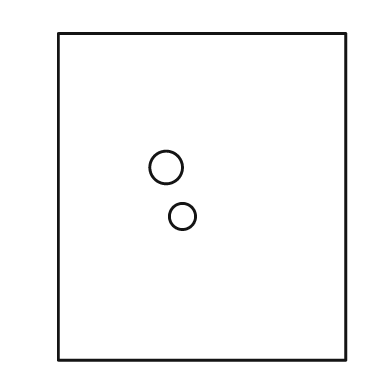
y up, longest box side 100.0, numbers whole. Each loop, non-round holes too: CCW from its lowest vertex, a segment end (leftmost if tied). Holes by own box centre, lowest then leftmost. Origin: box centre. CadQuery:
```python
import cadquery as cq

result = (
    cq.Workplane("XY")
    .moveTo(-44.0, -50.0)
    .lineTo(44.0, -50.0)
    .lineTo(44.0, 50.0)
    .lineTo(-44.0, 50.0)
    .close()
    .moveTo(-6.0, -6.0)
    .circle(4.0)
    .moveTo(-11.0, 9.0)
    .circle(5.0)
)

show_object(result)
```